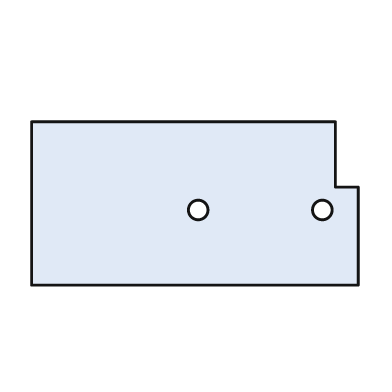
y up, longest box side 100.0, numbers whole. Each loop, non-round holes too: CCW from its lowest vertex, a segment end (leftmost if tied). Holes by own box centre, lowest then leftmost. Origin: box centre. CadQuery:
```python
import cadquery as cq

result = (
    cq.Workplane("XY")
    .moveTo(-50.0, -25.0)
    .lineTo(50.0, -25.0)
    .lineTo(50.0, 5.0)
    .lineTo(43.0, 5.0)
    .lineTo(43.0, 25.0)
    .lineTo(-50.0, 25.0)
    .close()
    .moveTo(1.0, -2.0)
    .circle(3.0)
    .moveTo(39.0, -2.0)
    .circle(3.0)
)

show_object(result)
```